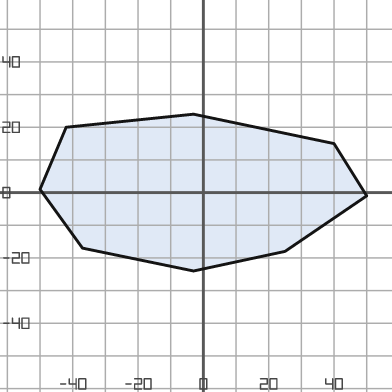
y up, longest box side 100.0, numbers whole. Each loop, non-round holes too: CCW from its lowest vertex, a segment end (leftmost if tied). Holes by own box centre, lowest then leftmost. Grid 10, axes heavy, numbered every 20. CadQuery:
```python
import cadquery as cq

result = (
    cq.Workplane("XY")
    .moveTo(-3.0, -24.0)
    .lineTo(25.0, -18.0)
    .lineTo(50.0, -1.0)
    .lineTo(40.0, 15.0)
    .lineTo(-3.0, 24.0)
    .lineTo(-42.0, 20.0)
    .lineTo(-50.0, 1.0)
    .lineTo(-37.0, -17.0)
    .close()
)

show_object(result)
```